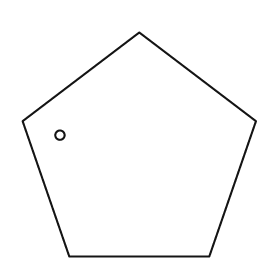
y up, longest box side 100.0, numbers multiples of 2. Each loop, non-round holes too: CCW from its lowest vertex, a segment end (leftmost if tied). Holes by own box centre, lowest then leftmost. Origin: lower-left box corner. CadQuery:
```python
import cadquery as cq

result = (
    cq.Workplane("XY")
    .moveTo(20.0, 0.0)
    .lineTo(80.0, 0.0)
    .lineTo(100.0, 58.0)
    .lineTo(50.0, 96.0)
    .lineTo(0.0, 58.0)
    .close()
    .moveTo(16.0, 52.0)
    .circle(2.0)
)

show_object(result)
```